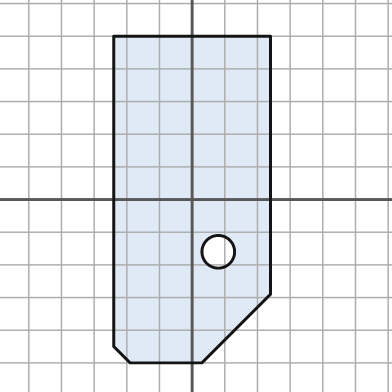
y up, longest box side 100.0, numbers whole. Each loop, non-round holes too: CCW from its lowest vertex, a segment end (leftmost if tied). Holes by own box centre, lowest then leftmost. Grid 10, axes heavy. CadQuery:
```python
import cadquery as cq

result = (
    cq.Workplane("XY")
    .moveTo(-19.0, -50.0)
    .lineTo(3.0, -50.0)
    .lineTo(24.0, -29.0)
    .lineTo(24.0, 50.0)
    .lineTo(-24.0, 50.0)
    .lineTo(-24.0, -45.0)
    .close()
    .moveTo(8.0, -16.0)
    .circle(5.0)
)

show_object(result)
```